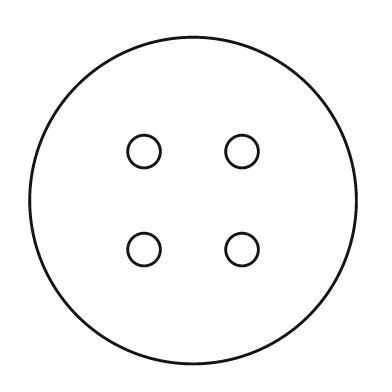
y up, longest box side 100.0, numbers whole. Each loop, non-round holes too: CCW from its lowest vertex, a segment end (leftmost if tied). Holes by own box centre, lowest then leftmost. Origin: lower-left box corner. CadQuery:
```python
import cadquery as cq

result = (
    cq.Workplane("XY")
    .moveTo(50.0, 50.0)
    .circle(50.0)
    .moveTo(35.0, 35.0)
    .circle(5.0)
    .moveTo(65.0, 35.0)
    .circle(5.0)
    .moveTo(35.0, 65.0)
    .circle(5.0)
    .moveTo(65.0, 65.0)
    .circle(5.0)
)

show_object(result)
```